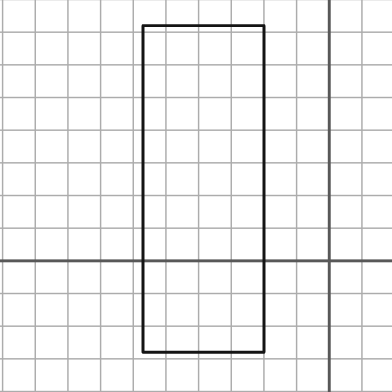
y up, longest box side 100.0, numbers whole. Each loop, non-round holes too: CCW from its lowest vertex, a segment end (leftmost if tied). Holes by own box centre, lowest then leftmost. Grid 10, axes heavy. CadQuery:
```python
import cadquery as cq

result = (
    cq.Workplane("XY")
    .moveTo(-57.0, -28.0)
    .lineTo(-20.0, -28.0)
    .lineTo(-20.0, 72.0)
    .lineTo(-57.0, 72.0)
    .close()
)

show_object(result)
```